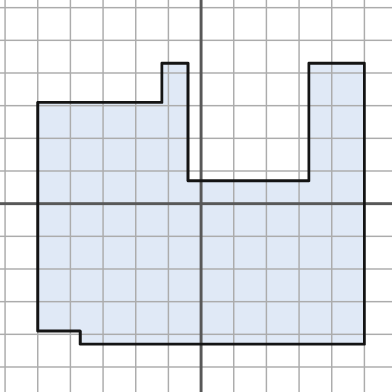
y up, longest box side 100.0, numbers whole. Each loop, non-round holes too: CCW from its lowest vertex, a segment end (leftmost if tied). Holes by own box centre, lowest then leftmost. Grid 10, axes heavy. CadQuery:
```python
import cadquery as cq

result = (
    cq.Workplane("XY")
    .moveTo(-37.0, -43.0)
    .lineTo(50.0, -43.0)
    .lineTo(50.0, 43.0)
    .lineTo(33.0, 43.0)
    .lineTo(33.0, 7.0)
    .lineTo(-4.0, 7.0)
    .lineTo(-4.0, 43.0)
    .lineTo(-12.0, 43.0)
    .lineTo(-12.0, 31.0)
    .lineTo(-50.0, 31.0)
    .lineTo(-50.0, -39.0)
    .lineTo(-37.0, -39.0)
    .close()
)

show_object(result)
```